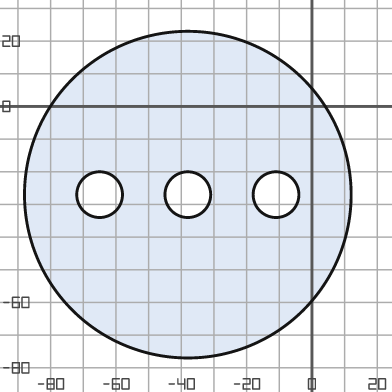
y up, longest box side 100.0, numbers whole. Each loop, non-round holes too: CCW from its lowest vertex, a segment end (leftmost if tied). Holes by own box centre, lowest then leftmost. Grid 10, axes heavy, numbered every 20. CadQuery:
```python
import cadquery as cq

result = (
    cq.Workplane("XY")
    .moveTo(-38.0, -27.0)
    .circle(50.0)
    .moveTo(-65.0, -27.0)
    .circle(7.0)
    .moveTo(-38.0, -27.0)
    .circle(7.0)
    .moveTo(-11.0, -27.0)
    .circle(7.0)
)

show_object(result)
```